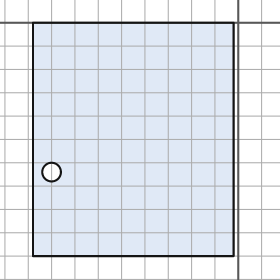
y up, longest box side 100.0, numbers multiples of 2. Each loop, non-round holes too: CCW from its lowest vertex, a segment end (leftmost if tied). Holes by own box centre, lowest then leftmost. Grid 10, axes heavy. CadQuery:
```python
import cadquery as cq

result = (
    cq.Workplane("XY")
    .moveTo(-88.0, -100.0)
    .lineTo(-2.0, -100.0)
    .lineTo(-2.0, 0.0)
    .lineTo(-88.0, 0.0)
    .close()
    .moveTo(-80.0, -64.0)
    .circle(4.0)
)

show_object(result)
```